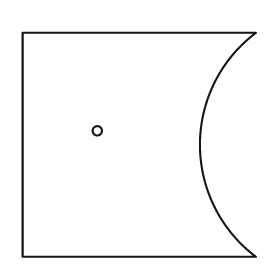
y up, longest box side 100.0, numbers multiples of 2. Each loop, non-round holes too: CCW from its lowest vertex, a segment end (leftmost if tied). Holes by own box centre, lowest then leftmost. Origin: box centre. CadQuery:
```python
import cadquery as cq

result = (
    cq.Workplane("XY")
    .moveTo(-50.0, -48.0)
    .lineTo(50.0, -48.0)
    .threePointArc((26.0, 0.0), (50.0, 48.0))
    .lineTo(-50.0, 48.0)
    .close()
    .moveTo(-18.0, 6.0)
    .circle(2.0)
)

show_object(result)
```